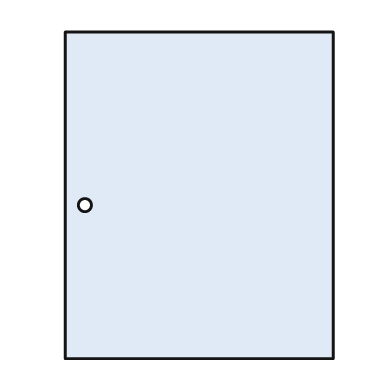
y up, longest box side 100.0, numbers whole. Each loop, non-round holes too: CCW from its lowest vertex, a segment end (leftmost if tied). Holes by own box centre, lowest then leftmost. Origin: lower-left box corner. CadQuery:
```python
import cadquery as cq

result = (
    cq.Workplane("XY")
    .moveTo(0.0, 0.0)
    .lineTo(82.0, 0.0)
    .lineTo(82.0, 100.0)
    .lineTo(0.0, 100.0)
    .close()
    .moveTo(6.0, 47.0)
    .circle(2.0)
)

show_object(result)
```